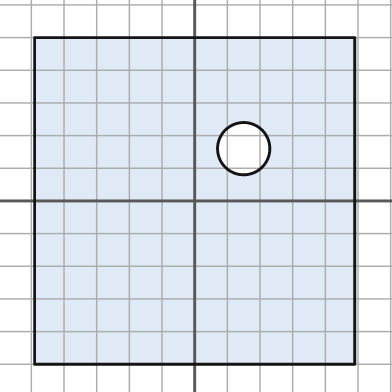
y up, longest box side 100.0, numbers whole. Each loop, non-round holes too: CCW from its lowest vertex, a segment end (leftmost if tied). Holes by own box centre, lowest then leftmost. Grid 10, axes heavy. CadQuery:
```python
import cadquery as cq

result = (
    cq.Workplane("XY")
    .moveTo(-49.0, -50.0)
    .lineTo(49.0, -50.0)
    .lineTo(49.0, 50.0)
    .lineTo(-49.0, 50.0)
    .close()
    .moveTo(15.0, 16.0)
    .circle(8.0)
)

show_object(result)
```